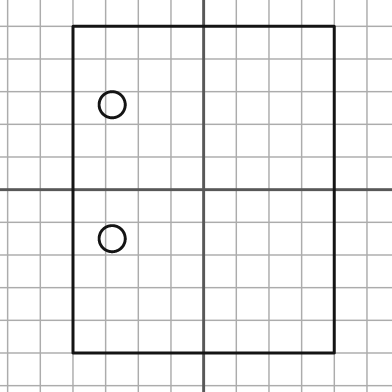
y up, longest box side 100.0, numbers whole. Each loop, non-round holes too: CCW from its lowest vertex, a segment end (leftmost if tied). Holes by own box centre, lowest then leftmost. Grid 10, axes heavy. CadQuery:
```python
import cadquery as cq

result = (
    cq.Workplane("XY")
    .moveTo(-40.0, -50.0)
    .lineTo(40.0, -50.0)
    .lineTo(40.0, 50.0)
    .lineTo(-40.0, 50.0)
    .close()
    .moveTo(-28.0, -15.0)
    .circle(4.0)
    .moveTo(-28.0, 26.0)
    .circle(4.0)
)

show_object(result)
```